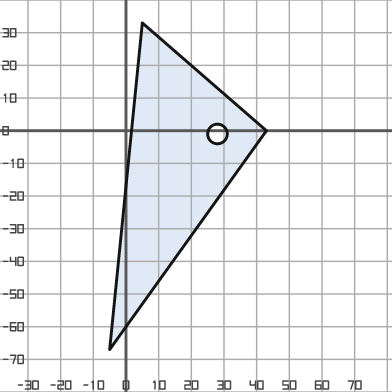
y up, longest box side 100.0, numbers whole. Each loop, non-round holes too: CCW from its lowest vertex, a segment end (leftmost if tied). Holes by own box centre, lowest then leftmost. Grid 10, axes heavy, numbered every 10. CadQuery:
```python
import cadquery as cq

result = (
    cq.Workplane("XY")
    .moveTo(-5.0, -67.0)
    .lineTo(43.0, 0.0)
    .lineTo(5.0, 33.0)
    .close()
    .moveTo(28.0, -1.0)
    .circle(3.0)
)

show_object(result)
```